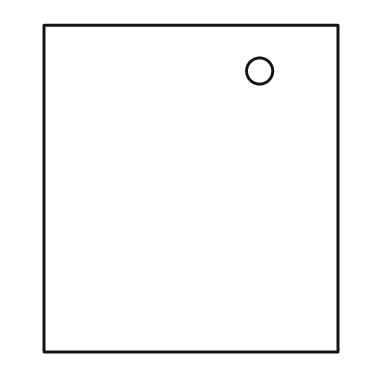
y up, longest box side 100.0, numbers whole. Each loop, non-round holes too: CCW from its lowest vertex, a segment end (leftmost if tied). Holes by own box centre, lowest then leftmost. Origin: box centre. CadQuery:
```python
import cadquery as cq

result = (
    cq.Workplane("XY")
    .moveTo(-45.0, -50.0)
    .lineTo(45.0, -50.0)
    .lineTo(45.0, 50.0)
    .lineTo(-45.0, 50.0)
    .close()
    .moveTo(21.0, 36.0)
    .circle(4.0)
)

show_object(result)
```